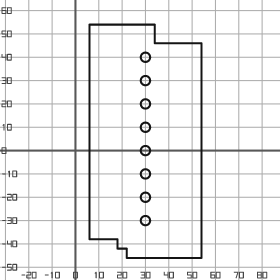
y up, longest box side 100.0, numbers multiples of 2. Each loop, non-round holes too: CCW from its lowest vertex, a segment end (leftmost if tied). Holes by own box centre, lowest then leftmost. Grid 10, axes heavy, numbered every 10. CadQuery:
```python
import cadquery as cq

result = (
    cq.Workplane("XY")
    .moveTo(22.0, -46.0)
    .lineTo(54.0, -46.0)
    .lineTo(54.0, 46.0)
    .lineTo(34.0, 46.0)
    .lineTo(34.0, 54.0)
    .lineTo(6.0, 54.0)
    .lineTo(6.0, -38.0)
    .lineTo(18.0, -38.0)
    .lineTo(18.0, -42.0)
    .lineTo(22.0, -42.0)
    .close()
    .moveTo(30.0, -30.0)
    .circle(2.0)
    .moveTo(30.0, -20.0)
    .circle(2.0)
    .moveTo(30.0, -10.0)
    .circle(2.0)
    .moveTo(30.0, 0.0)
    .circle(2.0)
    .moveTo(30.0, 10.0)
    .circle(2.0)
    .moveTo(30.0, 20.0)
    .circle(2.0)
    .moveTo(30.0, 30.0)
    .circle(2.0)
    .moveTo(30.0, 40.0)
    .circle(2.0)
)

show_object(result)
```